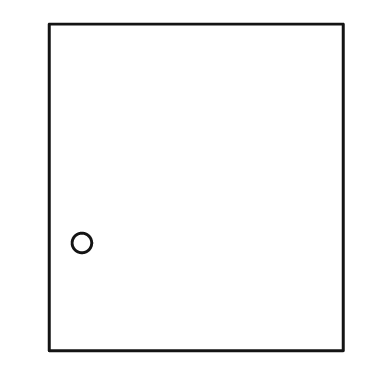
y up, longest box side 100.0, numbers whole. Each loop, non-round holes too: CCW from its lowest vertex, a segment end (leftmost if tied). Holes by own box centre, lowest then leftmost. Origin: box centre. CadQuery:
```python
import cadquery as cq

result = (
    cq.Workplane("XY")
    .moveTo(-45.0, -50.0)
    .lineTo(45.0, -50.0)
    .lineTo(45.0, 50.0)
    .lineTo(-45.0, 50.0)
    .close()
    .moveTo(-35.0, -17.0)
    .circle(3.0)
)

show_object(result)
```